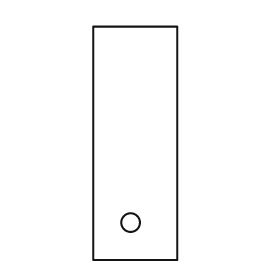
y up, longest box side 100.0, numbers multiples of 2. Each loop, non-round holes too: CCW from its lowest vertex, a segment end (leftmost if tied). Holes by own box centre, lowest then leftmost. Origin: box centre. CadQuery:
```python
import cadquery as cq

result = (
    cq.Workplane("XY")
    .moveTo(-18.0, -50.0)
    .lineTo(18.0, -50.0)
    .lineTo(18.0, 50.0)
    .lineTo(-18.0, 50.0)
    .close()
    .moveTo(-2.0, -34.0)
    .circle(4.0)
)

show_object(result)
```